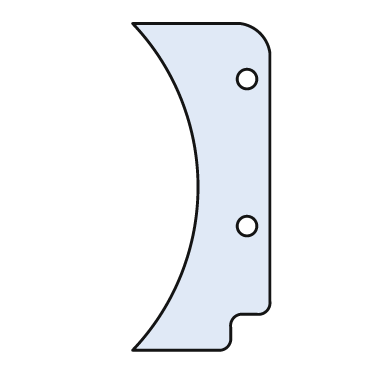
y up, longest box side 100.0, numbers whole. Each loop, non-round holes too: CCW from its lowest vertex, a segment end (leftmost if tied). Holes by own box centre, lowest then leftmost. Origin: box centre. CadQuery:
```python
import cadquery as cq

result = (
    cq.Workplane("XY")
    .moveTo(-21.0, -50.0)
    .lineTo(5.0, -50.0)
    .threePointArc((8.0, -49.0), (9.0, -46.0))
    .lineTo(9.0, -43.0)
    .threePointArc((10.0, -40.0), (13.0, -39.0))
    .lineTo(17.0, -39.0)
    .threePointArc((20.0, -38.0), (21.0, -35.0))
    .lineTo(21.0, 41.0)
    .threePointArc((18.0, 47.0), (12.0, 50.0))
    .lineTo(-21.0, 50.0)
    .threePointArc((-1.0, 0.0), (-21.0, -50.0))
    .close()
    .moveTo(14.0, -12.0)
    .circle(3.0)
    .moveTo(14.0, 33.0)
    .circle(3.0)
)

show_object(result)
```